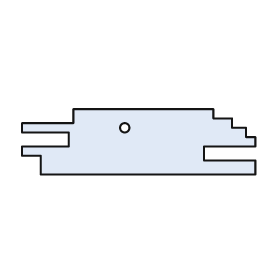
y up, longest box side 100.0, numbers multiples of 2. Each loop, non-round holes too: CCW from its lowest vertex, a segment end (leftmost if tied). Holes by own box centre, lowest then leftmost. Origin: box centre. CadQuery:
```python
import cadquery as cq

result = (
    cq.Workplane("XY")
    .moveTo(-42.0, -14.0)
    .lineTo(50.0, -14.0)
    .lineTo(50.0, -8.0)
    .lineTo(28.0, -8.0)
    .lineTo(28.0, -2.0)
    .lineTo(50.0, -2.0)
    .lineTo(50.0, 2.0)
    .lineTo(46.0, 2.0)
    .lineTo(46.0, 6.0)
    .lineTo(40.0, 6.0)
    .lineTo(40.0, 10.0)
    .lineTo(32.0, 10.0)
    .lineTo(32.0, 14.0)
    .lineTo(-28.0, 14.0)
    .lineTo(-28.0, 8.0)
    .lineTo(-50.0, 8.0)
    .lineTo(-50.0, 4.0)
    .lineTo(-30.0, 4.0)
    .lineTo(-30.0, -2.0)
    .lineTo(-50.0, -2.0)
    .lineTo(-50.0, -6.0)
    .lineTo(-42.0, -6.0)
    .close()
    .moveTo(-6.0, 6.0)
    .circle(2.0)
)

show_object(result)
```